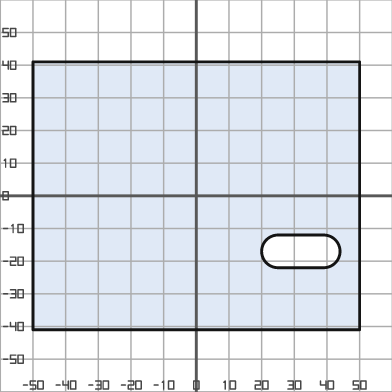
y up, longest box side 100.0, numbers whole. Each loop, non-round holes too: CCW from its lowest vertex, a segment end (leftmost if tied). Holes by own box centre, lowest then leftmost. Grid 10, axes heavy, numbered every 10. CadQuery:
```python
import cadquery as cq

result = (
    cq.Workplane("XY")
    .moveTo(-50.0, -41.0)
    .lineTo(50.0, -41.0)
    .lineTo(50.0, 41.0)
    .lineTo(-50.0, 41.0)
    .close()
    .moveTo(25.0, -22.0)
    .lineTo(39.0, -22.0)
    .threePointArc((44.0, -17.0), (39.0, -12.0))
    .lineTo(25.0, -12.0)
    .threePointArc((20.0, -17.0), (25.0, -22.0))
    .close()
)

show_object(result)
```